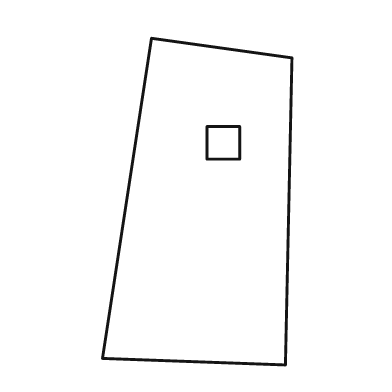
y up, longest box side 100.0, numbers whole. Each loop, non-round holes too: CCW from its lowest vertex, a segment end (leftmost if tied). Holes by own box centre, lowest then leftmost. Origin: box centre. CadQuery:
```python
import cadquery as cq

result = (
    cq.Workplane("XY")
    .moveTo(27.0, -50.0)
    .lineTo(29.0, 44.0)
    .lineTo(-14.0, 50.0)
    .lineTo(-29.0, -48.0)
    .close()
    .moveTo(3.0, 13.0)
    .lineTo(13.0, 13.0)
    .lineTo(13.0, 23.0)
    .lineTo(3.0, 23.0)
    .close()
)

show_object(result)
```